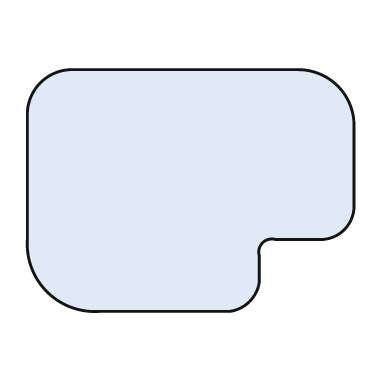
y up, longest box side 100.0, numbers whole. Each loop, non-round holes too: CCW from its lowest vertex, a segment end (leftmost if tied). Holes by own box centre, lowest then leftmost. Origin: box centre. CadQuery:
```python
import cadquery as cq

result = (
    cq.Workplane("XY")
    .moveTo(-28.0, -37.0)
    .lineTo(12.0, -37.0)
    .threePointArc((18.0, -34.0), (21.0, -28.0))
    .lineTo(21.0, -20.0)
    .threePointArc((22.0, -16.0), (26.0, -15.0))
    .lineTo(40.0, -15.0)
    .threePointArc((47.0, -12.0), (50.0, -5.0))
    .lineTo(50.0, 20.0)
    .threePointArc((45.0, 32.0), (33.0, 37.0))
    .lineTo(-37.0, 37.0)
    .threePointArc((-46.0, 33.0), (-50.0, 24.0))
    .lineTo(-50.0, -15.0)
    .threePointArc((-44.0, -31.0), (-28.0, -37.0))
    .close()
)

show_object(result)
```